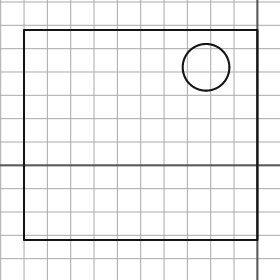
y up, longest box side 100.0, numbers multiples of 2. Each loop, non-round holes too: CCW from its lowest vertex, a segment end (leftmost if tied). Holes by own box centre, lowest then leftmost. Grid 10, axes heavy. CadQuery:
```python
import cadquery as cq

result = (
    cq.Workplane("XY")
    .moveTo(-100.0, -32.0)
    .lineTo(0.0, -32.0)
    .lineTo(0.0, 58.0)
    .lineTo(-100.0, 58.0)
    .close()
    .moveTo(-22.0, 42.0)
    .circle(10.0)
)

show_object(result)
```